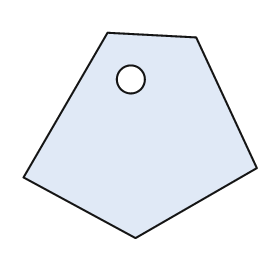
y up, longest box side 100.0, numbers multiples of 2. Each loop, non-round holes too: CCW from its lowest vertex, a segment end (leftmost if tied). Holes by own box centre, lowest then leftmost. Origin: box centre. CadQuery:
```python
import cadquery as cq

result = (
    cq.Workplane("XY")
    .moveTo(-2.0, -44.0)
    .lineTo(50.0, -14.0)
    .lineTo(24.0, 42.0)
    .lineTo(-14.0, 44.0)
    .lineTo(-50.0, -18.0)
    .close()
    .moveTo(-4.0, 24.0)
    .circle(6.0)
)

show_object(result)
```